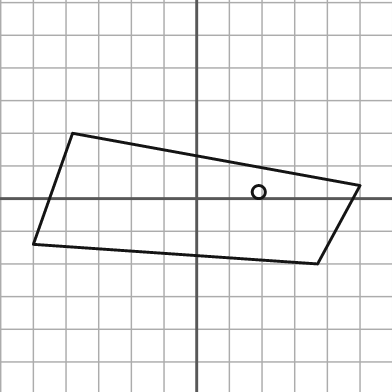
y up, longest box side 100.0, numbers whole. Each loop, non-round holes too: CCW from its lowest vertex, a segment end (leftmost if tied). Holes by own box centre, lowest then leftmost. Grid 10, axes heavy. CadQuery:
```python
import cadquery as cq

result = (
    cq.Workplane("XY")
    .moveTo(37.0, -20.0)
    .lineTo(50.0, 4.0)
    .lineTo(-38.0, 20.0)
    .lineTo(-50.0, -14.0)
    .close()
    .moveTo(19.0, 2.0)
    .circle(2.0)
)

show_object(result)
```